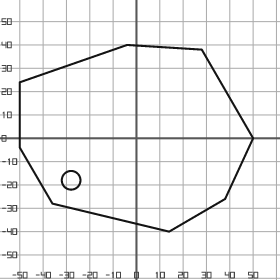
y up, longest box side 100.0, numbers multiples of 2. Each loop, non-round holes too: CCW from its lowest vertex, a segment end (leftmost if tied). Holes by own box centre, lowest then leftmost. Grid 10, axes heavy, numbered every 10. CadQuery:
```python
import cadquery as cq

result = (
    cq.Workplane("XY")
    .moveTo(14.0, -40.0)
    .lineTo(38.0, -26.0)
    .lineTo(50.0, 0.0)
    .lineTo(28.0, 38.0)
    .lineTo(-4.0, 40.0)
    .lineTo(-50.0, 24.0)
    .lineTo(-50.0, -4.0)
    .lineTo(-36.0, -28.0)
    .close()
    .moveTo(-28.0, -18.0)
    .circle(4.0)
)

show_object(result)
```